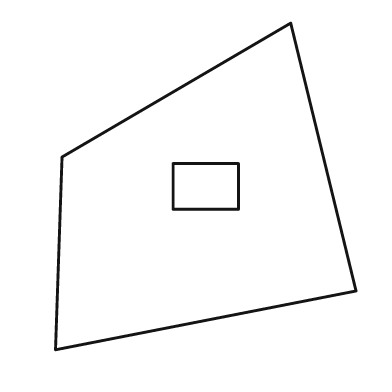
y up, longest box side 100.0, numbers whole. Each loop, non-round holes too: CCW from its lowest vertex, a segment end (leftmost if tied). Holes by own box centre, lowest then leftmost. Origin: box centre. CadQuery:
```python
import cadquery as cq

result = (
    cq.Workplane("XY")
    .moveTo(-46.0, -50.0)
    .lineTo(46.0, -32.0)
    .lineTo(26.0, 50.0)
    .lineTo(-44.0, 9.0)
    .close()
    .moveTo(-10.0, -7.0)
    .lineTo(10.0, -7.0)
    .lineTo(10.0, 7.0)
    .lineTo(-10.0, 7.0)
    .close()
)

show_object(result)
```